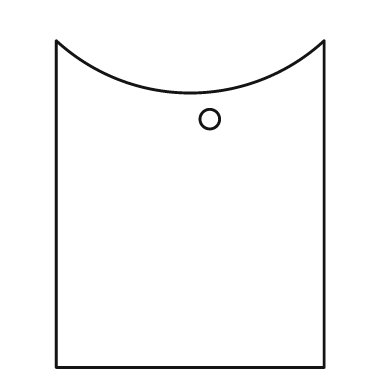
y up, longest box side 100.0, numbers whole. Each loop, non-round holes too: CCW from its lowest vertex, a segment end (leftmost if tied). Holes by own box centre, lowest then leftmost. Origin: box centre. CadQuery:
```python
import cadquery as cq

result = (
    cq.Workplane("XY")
    .moveTo(-41.0, -50.0)
    .lineTo(41.0, -50.0)
    .lineTo(41.0, 50.0)
    .threePointArc((0.0, 34.0), (-41.0, 50.0))
    .close()
    .moveTo(6.0, 26.0)
    .circle(3.0)
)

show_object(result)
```